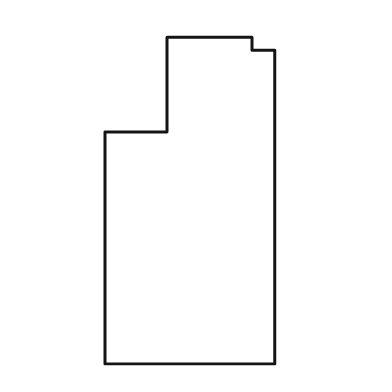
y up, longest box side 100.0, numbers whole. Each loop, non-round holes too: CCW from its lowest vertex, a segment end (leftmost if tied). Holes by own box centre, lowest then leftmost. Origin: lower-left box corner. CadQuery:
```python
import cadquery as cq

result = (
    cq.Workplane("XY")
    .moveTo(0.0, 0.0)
    .lineTo(52.0, 0.0)
    .lineTo(52.0, 96.0)
    .lineTo(45.0, 96.0)
    .lineTo(45.0, 100.0)
    .lineTo(19.0, 100.0)
    .lineTo(19.0, 71.0)
    .lineTo(0.0, 71.0)
    .close()
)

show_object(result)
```